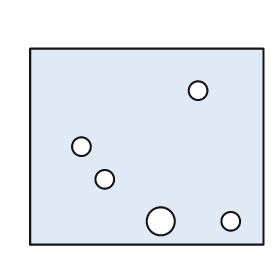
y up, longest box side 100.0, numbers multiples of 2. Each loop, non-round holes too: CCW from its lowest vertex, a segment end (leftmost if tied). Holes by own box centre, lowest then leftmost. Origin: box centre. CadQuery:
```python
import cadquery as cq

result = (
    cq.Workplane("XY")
    .moveTo(-50.0, -42.0)
    .lineTo(50.0, -42.0)
    .lineTo(50.0, 42.0)
    .lineTo(-50.0, 42.0)
    .close()
    .moveTo(6.0, -32.0)
    .circle(6.0)
    .moveTo(36.0, -32.0)
    .circle(4.0)
    .moveTo(-18.0, -14.0)
    .circle(4.0)
    .moveTo(-28.0, 0.0)
    .circle(4.0)
    .moveTo(22.0, 24.0)
    .circle(4.0)
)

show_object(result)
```